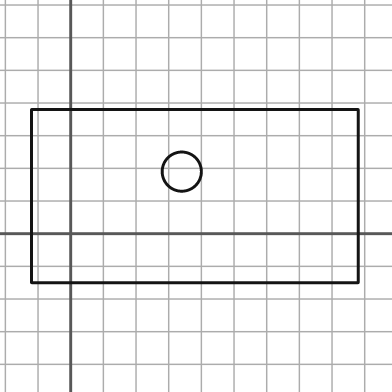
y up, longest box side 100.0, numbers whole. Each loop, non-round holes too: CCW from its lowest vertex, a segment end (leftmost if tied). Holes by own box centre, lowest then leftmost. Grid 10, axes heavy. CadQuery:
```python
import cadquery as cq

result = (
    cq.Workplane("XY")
    .moveTo(-12.0, -15.0)
    .lineTo(88.0, -15.0)
    .lineTo(88.0, 38.0)
    .lineTo(-12.0, 38.0)
    .close()
    .moveTo(34.0, 19.0)
    .circle(6.0)
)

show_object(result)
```